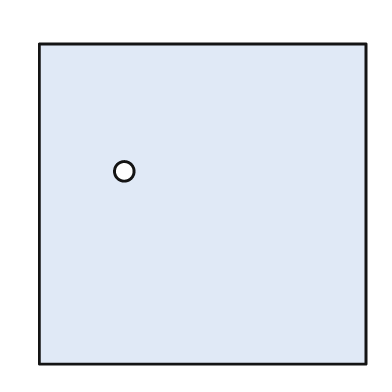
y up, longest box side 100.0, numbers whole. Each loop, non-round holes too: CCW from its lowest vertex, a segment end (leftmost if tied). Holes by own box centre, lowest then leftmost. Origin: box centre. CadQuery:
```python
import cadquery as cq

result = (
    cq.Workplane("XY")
    .moveTo(-50.0, -49.0)
    .lineTo(50.0, -49.0)
    .lineTo(50.0, 49.0)
    .lineTo(-50.0, 49.0)
    .close()
    .moveTo(-24.0, 10.0)
    .circle(3.0)
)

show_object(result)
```